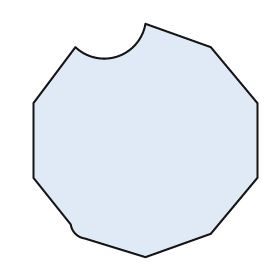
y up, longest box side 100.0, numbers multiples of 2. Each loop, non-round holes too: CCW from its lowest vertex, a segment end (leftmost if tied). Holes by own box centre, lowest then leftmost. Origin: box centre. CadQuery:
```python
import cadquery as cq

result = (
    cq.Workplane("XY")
    .moveTo(0.0, -50.0)
    .lineTo(28.0, -40.0)
    .lineTo(48.0, -16.0)
    .lineTo(48.0, 16.0)
    .lineTo(28.0, 40.0)
    .lineTo(0.0, 50.0)
    .threePointArc((-12.0, 36.0), (-30.0, 40.0))
    .lineTo(-48.0, 16.0)
    .lineTo(-48.0, -16.0)
    .lineTo(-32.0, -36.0)
    .threePointArc((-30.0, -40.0), (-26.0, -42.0))
    .close()
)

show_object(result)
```